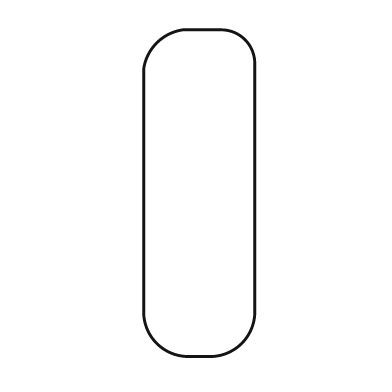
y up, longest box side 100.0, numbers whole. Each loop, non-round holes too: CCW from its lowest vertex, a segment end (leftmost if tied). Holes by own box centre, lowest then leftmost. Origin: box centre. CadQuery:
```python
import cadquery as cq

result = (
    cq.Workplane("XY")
    .moveTo(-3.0, -50.0)
    .lineTo(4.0, -50.0)
    .threePointArc((13.0, -46.0), (17.0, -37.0))
    .lineTo(17.0, 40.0)
    .threePointArc((14.0, 47.0), (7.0, 50.0))
    .lineTo(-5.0, 50.0)
    .threePointArc((-13.0, 46.0), (-17.0, 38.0))
    .lineTo(-17.0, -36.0)
    .threePointArc((-13.0, -46.0), (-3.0, -50.0))
    .close()
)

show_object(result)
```